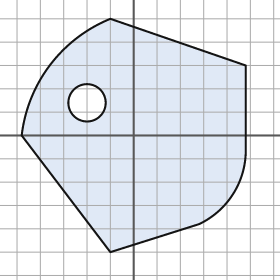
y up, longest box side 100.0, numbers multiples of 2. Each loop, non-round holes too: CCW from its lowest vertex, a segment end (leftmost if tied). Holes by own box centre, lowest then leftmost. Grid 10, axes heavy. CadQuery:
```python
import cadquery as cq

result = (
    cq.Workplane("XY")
    .moveTo(-10.0, -50.0)
    .lineTo(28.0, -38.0)
    .threePointArc((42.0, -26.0), (48.0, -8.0))
    .lineTo(48.0, 30.0)
    .lineTo(-10.0, 50.0)
    .threePointArc((-36.0, 30.0), (-48.0, 0.0))
    .close()
    .moveTo(-20.0, 14.0)
    .circle(8.0)
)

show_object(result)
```